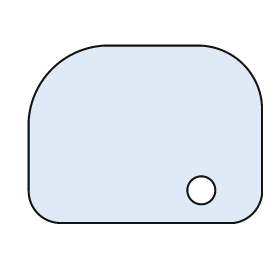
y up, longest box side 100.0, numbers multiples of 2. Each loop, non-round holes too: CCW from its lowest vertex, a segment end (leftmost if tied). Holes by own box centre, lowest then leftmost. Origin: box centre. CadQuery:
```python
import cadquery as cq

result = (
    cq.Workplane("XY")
    .moveTo(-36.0, -38.0)
    .lineTo(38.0, -38.0)
    .threePointArc((46.0, -34.0), (50.0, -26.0))
    .lineTo(50.0, 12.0)
    .threePointArc((42.0, 30.0), (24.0, 38.0))
    .lineTo(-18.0, 38.0)
    .threePointArc((-40.0, 28.0), (-50.0, 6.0))
    .lineTo(-50.0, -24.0)
    .threePointArc((-46.0, -34.0), (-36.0, -38.0))
    .close()
    .moveTo(24.0, -24.0)
    .circle(6.0)
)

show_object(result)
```